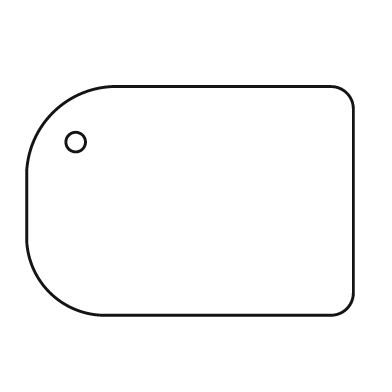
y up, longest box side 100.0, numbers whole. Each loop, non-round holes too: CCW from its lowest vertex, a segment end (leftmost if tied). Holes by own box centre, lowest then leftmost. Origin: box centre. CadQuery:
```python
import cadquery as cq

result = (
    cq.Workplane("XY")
    .moveTo(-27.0, -35.0)
    .lineTo(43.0, -35.0)
    .threePointArc((48.0, -33.0), (50.0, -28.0))
    .lineTo(50.0, 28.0)
    .threePointArc((48.0, 33.0), (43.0, 35.0))
    .lineTo(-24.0, 35.0)
    .threePointArc((-42.0, 27.0), (-50.0, 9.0))
    .lineTo(-50.0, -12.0)
    .threePointArc((-43.0, -28.0), (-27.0, -35.0))
    .close()
    .moveTo(-35.0, 18.0)
    .circle(3.0)
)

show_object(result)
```